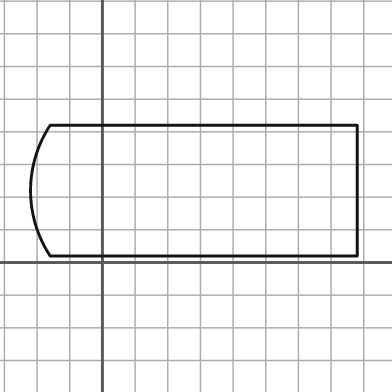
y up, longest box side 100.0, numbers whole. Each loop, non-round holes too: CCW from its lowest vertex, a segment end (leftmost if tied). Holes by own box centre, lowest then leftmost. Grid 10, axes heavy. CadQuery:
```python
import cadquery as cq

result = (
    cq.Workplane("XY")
    .moveTo(-16.0, 2.0)
    .lineTo(78.0, 2.0)
    .lineTo(78.0, 42.0)
    .lineTo(-16.0, 42.0)
    .threePointArc((-22.0, 22.0), (-16.0, 2.0))
    .close()
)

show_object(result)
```